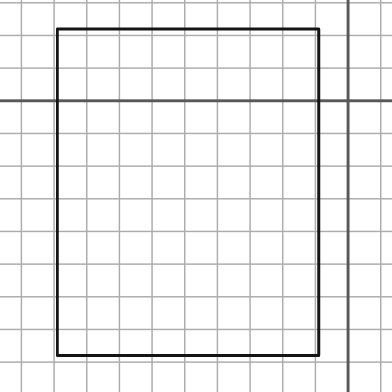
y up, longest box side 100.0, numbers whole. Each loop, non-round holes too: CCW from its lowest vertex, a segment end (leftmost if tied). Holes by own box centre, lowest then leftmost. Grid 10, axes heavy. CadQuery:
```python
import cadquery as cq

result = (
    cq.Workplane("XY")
    .moveTo(-89.0, -78.0)
    .lineTo(-9.0, -78.0)
    .lineTo(-9.0, 22.0)
    .lineTo(-89.0, 22.0)
    .close()
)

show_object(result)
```